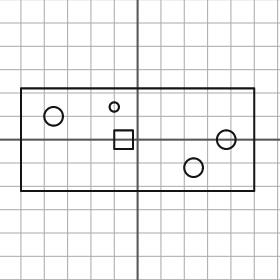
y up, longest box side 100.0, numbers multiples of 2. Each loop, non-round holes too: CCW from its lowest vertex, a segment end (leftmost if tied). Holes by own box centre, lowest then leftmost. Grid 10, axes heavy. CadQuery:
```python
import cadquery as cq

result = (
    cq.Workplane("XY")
    .moveTo(-50.0, -22.0)
    .lineTo(50.0, -22.0)
    .lineTo(50.0, 22.0)
    .lineTo(-50.0, 22.0)
    .close()
    .moveTo(24.0, -12.0)
    .circle(4.0)
    .moveTo(-10.0, -4.0)
    .lineTo(-2.0, -4.0)
    .lineTo(-2.0, 4.0)
    .lineTo(-10.0, 4.0)
    .close()
    .moveTo(38.0, 0.0)
    .circle(4.0)
    .moveTo(-36.0, 10.0)
    .circle(4.0)
    .moveTo(-10.0, 14.0)
    .circle(2.0)
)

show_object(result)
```